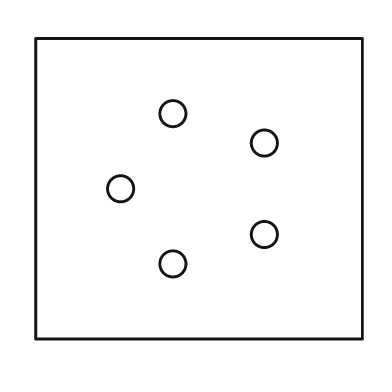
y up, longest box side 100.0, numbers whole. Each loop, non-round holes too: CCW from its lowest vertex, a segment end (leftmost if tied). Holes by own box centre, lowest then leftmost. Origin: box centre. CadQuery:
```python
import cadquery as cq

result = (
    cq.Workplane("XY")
    .moveTo(-50.0, -46.0)
    .lineTo(50.0, -46.0)
    .lineTo(50.0, 46.0)
    .lineTo(-50.0, 46.0)
    .close()
    .moveTo(-8.0, -23.0)
    .circle(4.0)
    .moveTo(20.0, -14.0)
    .circle(4.0)
    .moveTo(-24.0, 0.0)
    .circle(4.0)
    .moveTo(20.0, 14.0)
    .circle(4.0)
    .moveTo(-8.0, 23.0)
    .circle(4.0)
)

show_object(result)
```